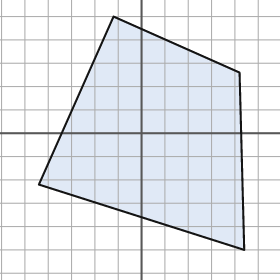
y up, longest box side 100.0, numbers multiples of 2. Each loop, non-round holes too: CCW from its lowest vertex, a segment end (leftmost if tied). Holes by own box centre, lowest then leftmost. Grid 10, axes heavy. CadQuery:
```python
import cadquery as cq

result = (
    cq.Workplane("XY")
    .moveTo(44.0, -50.0)
    .lineTo(42.0, 26.0)
    .lineTo(-12.0, 50.0)
    .lineTo(-44.0, -22.0)
    .close()
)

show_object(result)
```